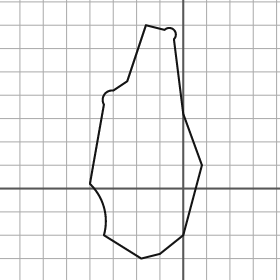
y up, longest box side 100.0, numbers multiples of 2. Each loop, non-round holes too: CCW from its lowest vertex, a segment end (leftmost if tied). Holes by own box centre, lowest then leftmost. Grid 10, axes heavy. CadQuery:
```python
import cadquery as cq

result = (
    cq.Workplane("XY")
    .moveTo(-18.0, -30.0)
    .lineTo(-10.0, -28.0)
    .lineTo(0.0, -20.0)
    .lineTo(8.0, 10.0)
    .lineTo(0.0, 32.0)
    .lineTo(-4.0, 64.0)
    .threePointArc((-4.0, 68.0), (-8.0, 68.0))
    .lineTo(-16.0, 70.0)
    .lineTo(-24.0, 46.0)
    .lineTo(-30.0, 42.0)
    .threePointArc((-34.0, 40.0), (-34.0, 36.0))
    .lineTo(-40.0, 2.0)
    .threePointArc((-34.0, -8.0), (-34.0, -20.0))
    .close()
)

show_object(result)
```